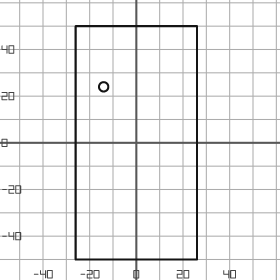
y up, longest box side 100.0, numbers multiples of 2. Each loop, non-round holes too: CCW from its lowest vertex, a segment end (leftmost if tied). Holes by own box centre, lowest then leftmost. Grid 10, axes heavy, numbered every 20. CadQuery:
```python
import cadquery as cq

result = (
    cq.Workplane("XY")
    .moveTo(-26.0, -50.0)
    .lineTo(26.0, -50.0)
    .lineTo(26.0, 50.0)
    .lineTo(-26.0, 50.0)
    .close()
    .moveTo(-14.0, 24.0)
    .circle(2.0)
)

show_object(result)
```